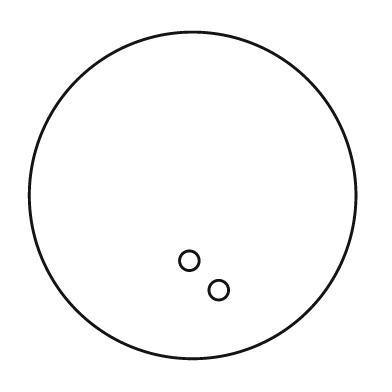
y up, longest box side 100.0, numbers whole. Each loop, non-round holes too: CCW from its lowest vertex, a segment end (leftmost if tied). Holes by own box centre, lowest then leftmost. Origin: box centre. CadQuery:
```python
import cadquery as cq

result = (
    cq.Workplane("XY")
    .moveTo(0.0, 0.0)
    .circle(50.0)
    .moveTo(8.0, -29.0)
    .circle(3.0)
    .moveTo(-1.0, -20.0)
    .circle(3.0)
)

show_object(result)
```